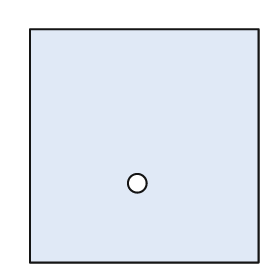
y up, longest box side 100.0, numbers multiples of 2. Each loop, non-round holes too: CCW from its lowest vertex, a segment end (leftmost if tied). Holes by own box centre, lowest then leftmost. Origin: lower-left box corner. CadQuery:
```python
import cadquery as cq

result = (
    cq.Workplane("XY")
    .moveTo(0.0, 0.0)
    .lineTo(98.0, 0.0)
    .lineTo(98.0, 100.0)
    .lineTo(0.0, 100.0)
    .close()
    .moveTo(46.0, 34.0)
    .circle(4.0)
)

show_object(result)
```